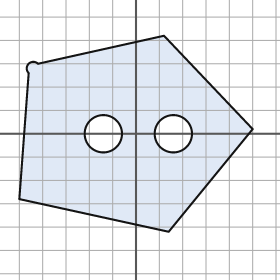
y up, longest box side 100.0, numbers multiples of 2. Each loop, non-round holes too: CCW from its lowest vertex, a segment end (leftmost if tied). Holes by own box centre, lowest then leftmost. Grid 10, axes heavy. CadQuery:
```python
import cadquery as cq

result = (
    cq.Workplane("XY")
    .moveTo(14.0, -42.0)
    .lineTo(50.0, 2.0)
    .lineTo(12.0, 42.0)
    .lineTo(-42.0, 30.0)
    .threePointArc((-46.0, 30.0), (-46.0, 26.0))
    .lineTo(-50.0, -28.0)
    .close()
    .moveTo(-14.0, 0.0)
    .circle(8.0)
    .moveTo(16.0, 0.0)
    .circle(8.0)
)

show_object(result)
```